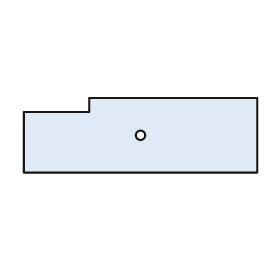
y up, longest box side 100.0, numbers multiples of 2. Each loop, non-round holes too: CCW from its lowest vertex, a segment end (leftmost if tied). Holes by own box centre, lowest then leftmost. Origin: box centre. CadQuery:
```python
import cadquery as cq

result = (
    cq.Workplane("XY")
    .moveTo(-50.0, -16.0)
    .lineTo(50.0, -16.0)
    .lineTo(50.0, 16.0)
    .lineTo(-22.0, 16.0)
    .lineTo(-22.0, 10.0)
    .lineTo(-50.0, 10.0)
    .close()
    .moveTo(0.0, 0.0)
    .circle(2.0)
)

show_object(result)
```